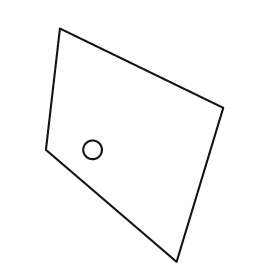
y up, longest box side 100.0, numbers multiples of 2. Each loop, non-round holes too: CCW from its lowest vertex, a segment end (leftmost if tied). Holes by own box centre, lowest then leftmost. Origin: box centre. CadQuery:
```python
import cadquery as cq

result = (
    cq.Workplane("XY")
    .moveTo(18.0, -50.0)
    .lineTo(38.0, 16.0)
    .lineTo(-32.0, 50.0)
    .lineTo(-38.0, -2.0)
    .close()
    .moveTo(-18.0, -2.0)
    .circle(4.0)
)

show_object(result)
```